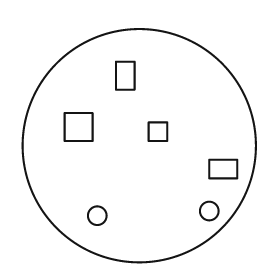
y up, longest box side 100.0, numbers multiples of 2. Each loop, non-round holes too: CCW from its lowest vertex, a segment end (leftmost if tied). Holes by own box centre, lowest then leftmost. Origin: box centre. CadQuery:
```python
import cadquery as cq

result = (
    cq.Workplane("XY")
    .moveTo(0.0, 0.0)
    .circle(50.0)
    .moveTo(-18.0, -30.0)
    .circle(4.0)
    .moveTo(30.0, -28.0)
    .circle(4.0)
    .moveTo(30.0, -14.0)
    .lineTo(42.0, -14.0)
    .lineTo(42.0, -6.0)
    .lineTo(30.0, -6.0)
    .close()
    .moveTo(4.0, 2.0)
    .lineTo(12.0, 2.0)
    .lineTo(12.0, 10.0)
    .lineTo(4.0, 10.0)
    .close()
    .moveTo(-32.0, 2.0)
    .lineTo(-20.0, 2.0)
    .lineTo(-20.0, 14.0)
    .lineTo(-32.0, 14.0)
    .close()
    .moveTo(-10.0, 24.0)
    .lineTo(-2.0, 24.0)
    .lineTo(-2.0, 36.0)
    .lineTo(-10.0, 36.0)
    .close()
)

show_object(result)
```